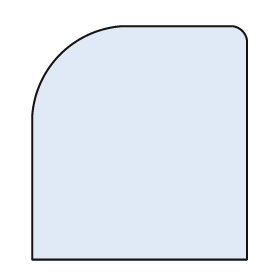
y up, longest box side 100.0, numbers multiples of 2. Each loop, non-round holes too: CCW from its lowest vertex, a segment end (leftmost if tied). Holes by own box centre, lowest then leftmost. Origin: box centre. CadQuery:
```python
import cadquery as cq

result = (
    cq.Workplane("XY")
    .moveTo(-46.0, -50.0)
    .lineTo(46.0, -50.0)
    .lineTo(46.0, 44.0)
    .threePointArc((44.0, 48.0), (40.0, 50.0))
    .lineTo(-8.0, 50.0)
    .threePointArc((-34.0, 38.0), (-46.0, 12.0))
    .close()
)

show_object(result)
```